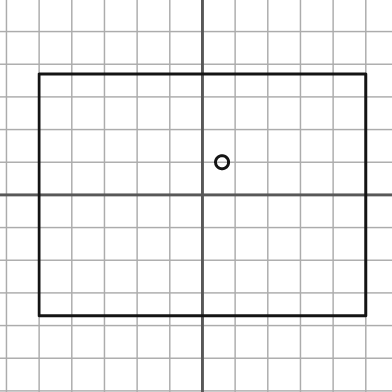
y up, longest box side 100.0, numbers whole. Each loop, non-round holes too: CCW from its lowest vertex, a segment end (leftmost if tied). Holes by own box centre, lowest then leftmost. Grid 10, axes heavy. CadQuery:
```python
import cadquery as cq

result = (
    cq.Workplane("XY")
    .moveTo(-50.0, -37.0)
    .lineTo(50.0, -37.0)
    .lineTo(50.0, 37.0)
    .lineTo(-50.0, 37.0)
    .close()
    .moveTo(6.0, 10.0)
    .circle(2.0)
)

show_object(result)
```